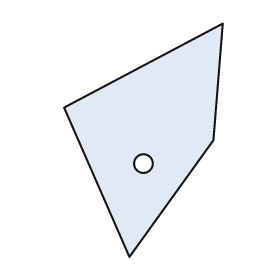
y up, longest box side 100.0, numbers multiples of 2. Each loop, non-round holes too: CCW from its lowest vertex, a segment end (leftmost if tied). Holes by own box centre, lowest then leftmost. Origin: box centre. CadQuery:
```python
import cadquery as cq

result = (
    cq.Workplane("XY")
    .moveTo(-6.0, -50.0)
    .lineTo(30.0, 0.0)
    .lineTo(34.0, 50.0)
    .lineTo(-34.0, 14.0)
    .close()
    .moveTo(0.0, -10.0)
    .circle(4.0)
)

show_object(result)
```